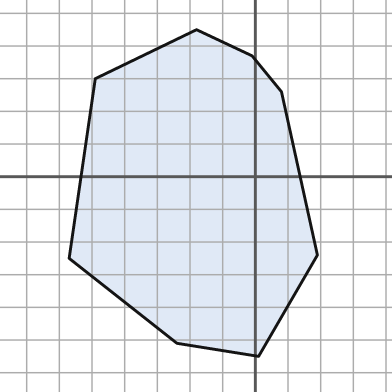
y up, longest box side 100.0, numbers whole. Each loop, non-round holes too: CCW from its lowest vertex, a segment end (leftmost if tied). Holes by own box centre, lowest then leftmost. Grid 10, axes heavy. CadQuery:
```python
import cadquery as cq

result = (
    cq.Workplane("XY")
    .moveTo(1.0, -55.0)
    .lineTo(19.0, -24.0)
    .lineTo(8.0, 26.0)
    .lineTo(-1.0, 37.0)
    .lineTo(-18.0, 45.0)
    .lineTo(-49.0, 30.0)
    .lineTo(-57.0, -25.0)
    .lineTo(-24.0, -51.0)
    .close()
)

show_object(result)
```